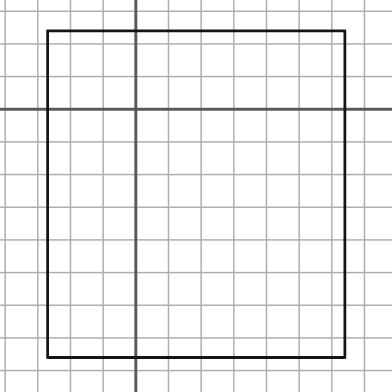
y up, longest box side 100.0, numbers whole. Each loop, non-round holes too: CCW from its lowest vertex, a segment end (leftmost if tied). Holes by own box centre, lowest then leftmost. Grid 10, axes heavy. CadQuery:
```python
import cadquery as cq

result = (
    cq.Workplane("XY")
    .moveTo(-27.0, -76.0)
    .lineTo(64.0, -76.0)
    .lineTo(64.0, 24.0)
    .lineTo(-27.0, 24.0)
    .close()
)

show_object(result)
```